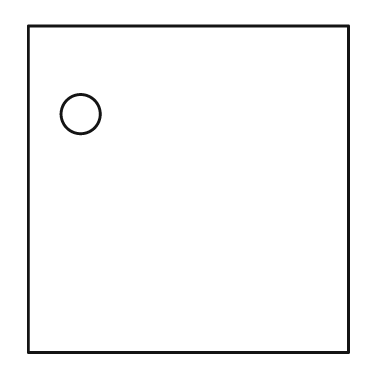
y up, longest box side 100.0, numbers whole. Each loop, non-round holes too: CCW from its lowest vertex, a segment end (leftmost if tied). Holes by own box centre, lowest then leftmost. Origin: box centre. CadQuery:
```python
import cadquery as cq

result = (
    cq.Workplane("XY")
    .moveTo(-49.0, -50.0)
    .lineTo(49.0, -50.0)
    .lineTo(49.0, 50.0)
    .lineTo(-49.0, 50.0)
    .close()
    .moveTo(-33.0, 23.0)
    .circle(6.0)
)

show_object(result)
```